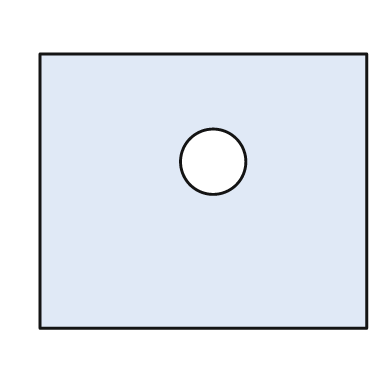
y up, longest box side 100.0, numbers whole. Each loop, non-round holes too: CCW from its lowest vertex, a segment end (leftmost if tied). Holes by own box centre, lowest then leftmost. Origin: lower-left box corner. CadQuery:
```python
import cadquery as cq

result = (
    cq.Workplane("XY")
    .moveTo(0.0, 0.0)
    .lineTo(100.0, 0.0)
    .lineTo(100.0, 84.0)
    .lineTo(0.0, 84.0)
    .close()
    .moveTo(53.0, 51.0)
    .circle(10.0)
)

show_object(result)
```